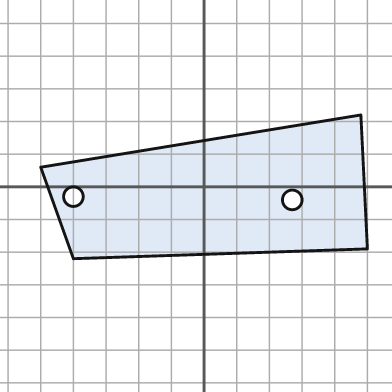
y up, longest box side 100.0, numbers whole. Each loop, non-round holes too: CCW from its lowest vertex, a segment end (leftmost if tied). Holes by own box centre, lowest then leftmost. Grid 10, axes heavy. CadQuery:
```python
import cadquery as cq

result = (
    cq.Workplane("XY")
    .moveTo(-40.0, -22.0)
    .lineTo(50.0, -19.0)
    .lineTo(48.0, 22.0)
    .lineTo(-50.0, 6.0)
    .close()
    .moveTo(27.0, -4.0)
    .circle(3.0)
    .moveTo(-40.0, -3.0)
    .circle(3.0)
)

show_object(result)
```